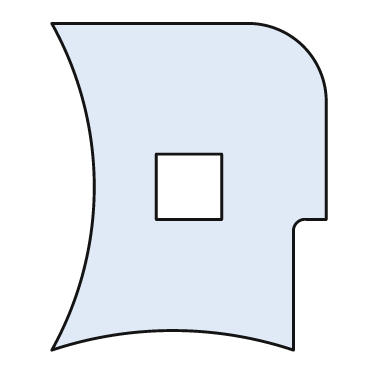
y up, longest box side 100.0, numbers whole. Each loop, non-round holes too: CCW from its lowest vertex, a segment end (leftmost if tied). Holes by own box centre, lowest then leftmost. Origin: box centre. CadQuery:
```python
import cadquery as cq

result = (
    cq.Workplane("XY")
    .moveTo(-42.0, -50.0)
    .threePointArc((-5.0, -44.0), (32.0, -50.0))
    .lineTo(32.0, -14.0)
    .threePointArc((33.0, -11.0), (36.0, -10.0))
    .lineTo(42.0, -10.0)
    .lineTo(42.0, 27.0)
    .threePointArc((35.0, 43.0), (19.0, 50.0))
    .lineTo(-42.0, 50.0)
    .threePointArc((-29.0, 0.0), (-42.0, -50.0))
    .close()
    .moveTo(-10.0, -10.0)
    .lineTo(10.0, -10.0)
    .lineTo(10.0, 10.0)
    .lineTo(-10.0, 10.0)
    .close()
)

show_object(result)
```